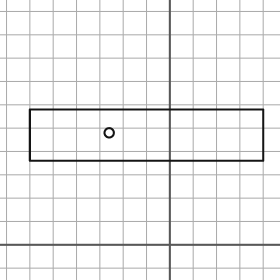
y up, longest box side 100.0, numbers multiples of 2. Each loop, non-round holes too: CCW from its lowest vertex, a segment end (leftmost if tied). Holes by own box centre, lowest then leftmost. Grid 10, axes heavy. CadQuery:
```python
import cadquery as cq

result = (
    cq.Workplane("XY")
    .moveTo(-60.0, 36.0)
    .lineTo(40.0, 36.0)
    .lineTo(40.0, 58.0)
    .lineTo(-60.0, 58.0)
    .close()
    .moveTo(-26.0, 48.0)
    .circle(2.0)
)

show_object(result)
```